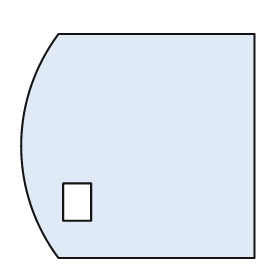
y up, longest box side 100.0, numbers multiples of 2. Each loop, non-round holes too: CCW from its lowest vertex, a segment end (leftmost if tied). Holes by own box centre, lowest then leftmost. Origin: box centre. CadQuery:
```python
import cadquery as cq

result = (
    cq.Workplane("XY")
    .moveTo(-34.0, -48.0)
    .lineTo(50.0, -48.0)
    .lineTo(50.0, 48.0)
    .lineTo(-34.0, 48.0)
    .threePointArc((-50.0, 0.0), (-34.0, -48.0))
    .close()
    .moveTo(-32.0, -32.0)
    .lineTo(-20.0, -32.0)
    .lineTo(-20.0, -16.0)
    .lineTo(-32.0, -16.0)
    .close()
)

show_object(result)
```